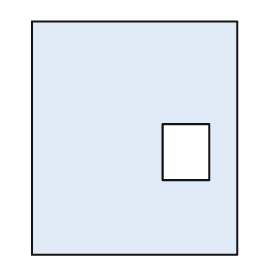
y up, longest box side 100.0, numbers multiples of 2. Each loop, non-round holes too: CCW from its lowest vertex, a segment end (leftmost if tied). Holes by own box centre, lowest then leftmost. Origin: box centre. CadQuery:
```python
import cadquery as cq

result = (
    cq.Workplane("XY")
    .moveTo(-44.0, -50.0)
    .lineTo(44.0, -50.0)
    .lineTo(44.0, 50.0)
    .lineTo(-44.0, 50.0)
    .close()
    .moveTo(12.0, -18.0)
    .lineTo(32.0, -18.0)
    .lineTo(32.0, 6.0)
    .lineTo(12.0, 6.0)
    .close()
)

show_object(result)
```